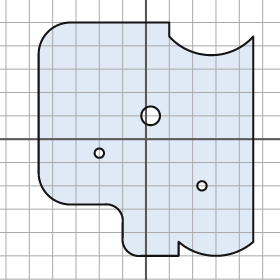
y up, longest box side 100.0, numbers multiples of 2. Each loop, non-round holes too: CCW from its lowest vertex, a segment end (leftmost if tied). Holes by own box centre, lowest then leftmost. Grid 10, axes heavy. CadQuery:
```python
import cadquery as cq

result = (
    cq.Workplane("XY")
    .moveTo(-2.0, -50.0)
    .lineTo(14.0, -50.0)
    .lineTo(14.0, -44.0)
    .threePointArc((30.0, -50.0), (46.0, -44.0))
    .lineTo(46.0, 44.0)
    .threePointArc((28.0, 36.0), (10.0, 44.0))
    .lineTo(10.0, 50.0)
    .lineTo(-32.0, 50.0)
    .threePointArc((-42.0, 46.0), (-46.0, 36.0))
    .lineTo(-46.0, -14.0)
    .threePointArc((-42.0, -24.0), (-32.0, -28.0))
    .lineTo(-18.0, -28.0)
    .threePointArc((-12.0, -30.0), (-10.0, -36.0))
    .lineTo(-10.0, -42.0)
    .threePointArc((-8.0, -48.0), (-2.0, -50.0))
    .close()
    .moveTo(24.0, -20.0)
    .circle(2.0)
    .moveTo(-20.0, -6.0)
    .circle(2.0)
    .moveTo(2.0, 10.0)
    .circle(4.0)
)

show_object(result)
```